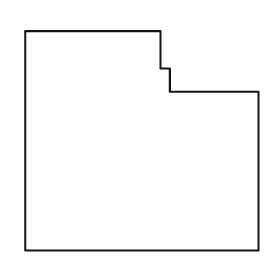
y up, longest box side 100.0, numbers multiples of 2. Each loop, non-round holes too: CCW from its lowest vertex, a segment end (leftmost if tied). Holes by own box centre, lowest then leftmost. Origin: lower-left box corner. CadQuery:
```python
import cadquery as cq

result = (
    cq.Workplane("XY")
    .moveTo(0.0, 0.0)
    .lineTo(100.0, 0.0)
    .lineTo(100.0, 68.0)
    .lineTo(62.0, 68.0)
    .lineTo(62.0, 78.0)
    .lineTo(58.0, 78.0)
    .lineTo(58.0, 94.0)
    .lineTo(0.0, 94.0)
    .close()
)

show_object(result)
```